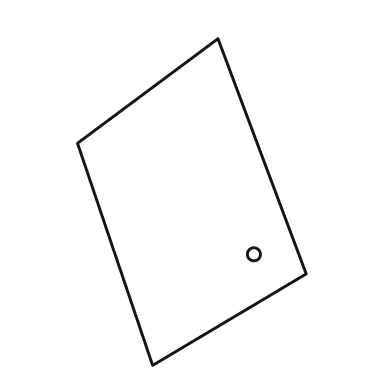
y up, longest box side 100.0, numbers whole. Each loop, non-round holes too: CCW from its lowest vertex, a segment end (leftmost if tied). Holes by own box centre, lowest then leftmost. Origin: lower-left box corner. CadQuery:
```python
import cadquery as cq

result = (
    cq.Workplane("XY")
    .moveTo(23.0, 0.0)
    .lineTo(70.0, 28.0)
    .lineTo(43.0, 100.0)
    .lineTo(0.0, 68.0)
    .close()
    .moveTo(54.0, 34.0)
    .circle(2.0)
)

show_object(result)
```